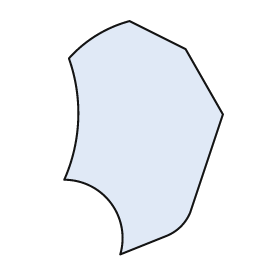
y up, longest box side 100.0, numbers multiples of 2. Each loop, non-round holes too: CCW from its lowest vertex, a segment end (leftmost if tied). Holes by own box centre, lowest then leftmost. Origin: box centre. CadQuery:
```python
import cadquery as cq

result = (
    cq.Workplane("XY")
    .moveTo(-10.0, -50.0)
    .lineTo(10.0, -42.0)
    .threePointArc((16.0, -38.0), (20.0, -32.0))
    .lineTo(34.0, 10.0)
    .lineTo(18.0, 38.0)
    .lineTo(-6.0, 50.0)
    .threePointArc((-20.0, 44.0), (-32.0, 34.0))
    .threePointArc((-28.0, 8.0), (-34.0, -18.0))
    .threePointArc((-14.0, -28.0), (-10.0, -50.0))
    .close()
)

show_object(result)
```